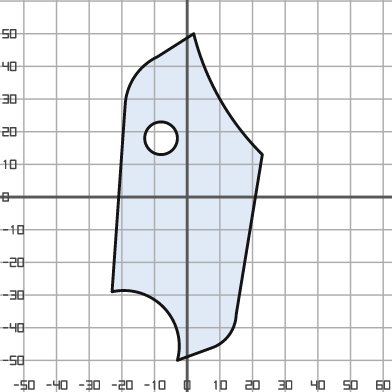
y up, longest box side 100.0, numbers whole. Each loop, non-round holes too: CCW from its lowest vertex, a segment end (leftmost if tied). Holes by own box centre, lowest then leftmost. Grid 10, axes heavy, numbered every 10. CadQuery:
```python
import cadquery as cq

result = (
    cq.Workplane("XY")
    .moveTo(-3.0, -50.0)
    .lineTo(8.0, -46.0)
    .threePointArc((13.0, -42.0), (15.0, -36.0))
    .lineTo(23.0, 13.0)
    .threePointArc((10.0, 30.0), (2.0, 50.0))
    .lineTo(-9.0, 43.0)
    .threePointArc((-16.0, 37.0), (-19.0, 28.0))
    .lineTo(-23.0, -29.0)
    .threePointArc((-7.0, -34.0), (-3.0, -50.0))
    .close()
    .moveTo(-8.0, 18.0)
    .circle(5.0)
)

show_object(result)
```